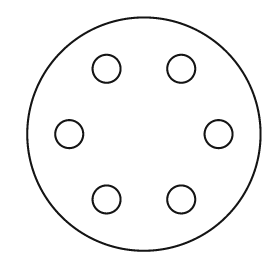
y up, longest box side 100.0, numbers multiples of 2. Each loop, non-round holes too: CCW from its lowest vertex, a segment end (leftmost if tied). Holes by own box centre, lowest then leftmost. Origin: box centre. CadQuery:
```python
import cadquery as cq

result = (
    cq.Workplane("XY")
    .moveTo(0.0, 0.0)
    .circle(50.0)
    .moveTo(-16.0, -28.0)
    .circle(6.0)
    .moveTo(16.0, -28.0)
    .circle(6.0)
    .moveTo(-32.0, 0.0)
    .circle(6.0)
    .moveTo(32.0, 0.0)
    .circle(6.0)
    .moveTo(-16.0, 28.0)
    .circle(6.0)
    .moveTo(16.0, 28.0)
    .circle(6.0)
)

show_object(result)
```